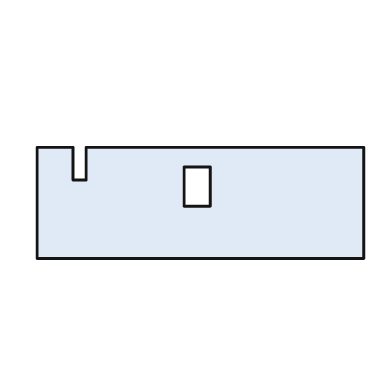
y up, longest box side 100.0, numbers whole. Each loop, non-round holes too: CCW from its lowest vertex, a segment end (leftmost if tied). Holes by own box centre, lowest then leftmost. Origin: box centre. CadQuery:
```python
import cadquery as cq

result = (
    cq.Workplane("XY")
    .moveTo(-50.0, -17.0)
    .lineTo(50.0, -17.0)
    .lineTo(50.0, 17.0)
    .lineTo(-35.0, 17.0)
    .lineTo(-35.0, 7.0)
    .lineTo(-39.0, 7.0)
    .lineTo(-39.0, 17.0)
    .lineTo(-50.0, 17.0)
    .close()
    .moveTo(-5.0, -1.0)
    .lineTo(3.0, -1.0)
    .lineTo(3.0, 11.0)
    .lineTo(-5.0, 11.0)
    .close()
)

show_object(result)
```